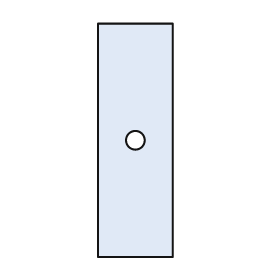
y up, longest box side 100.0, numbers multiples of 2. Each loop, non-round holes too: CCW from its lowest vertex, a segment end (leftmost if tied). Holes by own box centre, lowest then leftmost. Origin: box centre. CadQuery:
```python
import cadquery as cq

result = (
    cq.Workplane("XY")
    .moveTo(-16.0, -50.0)
    .lineTo(16.0, -50.0)
    .lineTo(16.0, 50.0)
    .lineTo(-16.0, 50.0)
    .close()
    .moveTo(0.0, 0.0)
    .circle(4.0)
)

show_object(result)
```